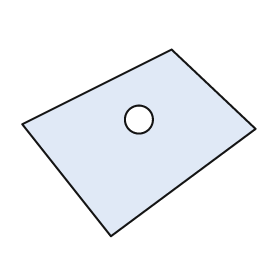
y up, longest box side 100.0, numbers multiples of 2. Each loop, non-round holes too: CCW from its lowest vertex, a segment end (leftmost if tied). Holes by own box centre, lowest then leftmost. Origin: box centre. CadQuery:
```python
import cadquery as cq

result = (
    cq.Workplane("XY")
    .moveTo(-12.0, -40.0)
    .lineTo(50.0, 6.0)
    .lineTo(14.0, 40.0)
    .lineTo(-50.0, 8.0)
    .close()
    .moveTo(0.0, 10.0)
    .circle(6.0)
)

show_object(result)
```